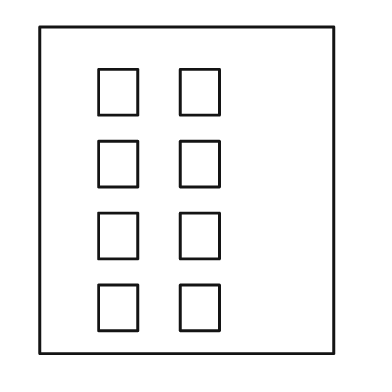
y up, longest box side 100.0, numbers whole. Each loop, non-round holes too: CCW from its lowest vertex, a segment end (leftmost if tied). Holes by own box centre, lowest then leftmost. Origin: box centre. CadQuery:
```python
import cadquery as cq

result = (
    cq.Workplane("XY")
    .moveTo(-45.0, -50.0)
    .lineTo(45.0, -50.0)
    .lineTo(45.0, 50.0)
    .lineTo(-45.0, 50.0)
    .close()
    .moveTo(-27.0, -43.0)
    .lineTo(-15.0, -43.0)
    .lineTo(-15.0, -29.0)
    .lineTo(-27.0, -29.0)
    .close()
    .moveTo(-2.0, -43.0)
    .lineTo(10.0, -43.0)
    .lineTo(10.0, -29.0)
    .lineTo(-2.0, -29.0)
    .close()
    .moveTo(-27.0, -21.0)
    .lineTo(-15.0, -21.0)
    .lineTo(-15.0, -7.0)
    .lineTo(-27.0, -7.0)
    .close()
    .moveTo(-2.0, -21.0)
    .lineTo(10.0, -21.0)
    .lineTo(10.0, -7.0)
    .lineTo(-2.0, -7.0)
    .close()
    .moveTo(-27.0, 1.0)
    .lineTo(-15.0, 1.0)
    .lineTo(-15.0, 15.0)
    .lineTo(-27.0, 15.0)
    .close()
    .moveTo(-2.0, 1.0)
    .lineTo(10.0, 1.0)
    .lineTo(10.0, 15.0)
    .lineTo(-2.0, 15.0)
    .close()
    .moveTo(-27.0, 23.0)
    .lineTo(-15.0, 23.0)
    .lineTo(-15.0, 37.0)
    .lineTo(-27.0, 37.0)
    .close()
    .moveTo(-2.0, 23.0)
    .lineTo(10.0, 23.0)
    .lineTo(10.0, 37.0)
    .lineTo(-2.0, 37.0)
    .close()
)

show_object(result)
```